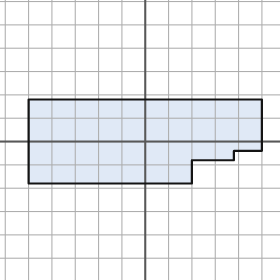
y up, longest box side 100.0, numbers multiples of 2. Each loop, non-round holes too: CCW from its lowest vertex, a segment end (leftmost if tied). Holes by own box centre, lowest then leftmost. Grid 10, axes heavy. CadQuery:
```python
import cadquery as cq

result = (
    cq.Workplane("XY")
    .moveTo(-50.0, -18.0)
    .lineTo(20.0, -18.0)
    .lineTo(20.0, -8.0)
    .lineTo(38.0, -8.0)
    .lineTo(38.0, -4.0)
    .lineTo(50.0, -4.0)
    .lineTo(50.0, 18.0)
    .lineTo(-50.0, 18.0)
    .close()
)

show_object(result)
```